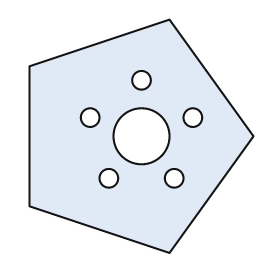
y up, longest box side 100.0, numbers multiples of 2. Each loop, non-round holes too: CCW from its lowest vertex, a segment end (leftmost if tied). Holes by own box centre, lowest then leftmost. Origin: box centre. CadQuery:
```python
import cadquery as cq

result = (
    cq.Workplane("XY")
    .moveTo(12.0, -50.0)
    .lineTo(48.0, 0.0)
    .lineTo(12.0, 50.0)
    .lineTo(-48.0, 30.0)
    .lineTo(-48.0, -30.0)
    .close()
    .moveTo(-14.0, -18.0)
    .circle(4.0)
    .moveTo(14.0, -18.0)
    .circle(4.0)
    .moveTo(0.0, 0.0)
    .circle(12.0)
    .moveTo(-22.0, 8.0)
    .circle(4.0)
    .moveTo(22.0, 8.0)
    .circle(4.0)
    .moveTo(0.0, 24.0)
    .circle(4.0)
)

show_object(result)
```